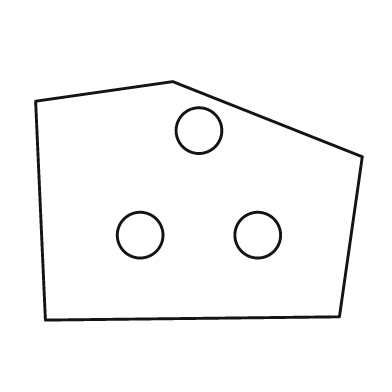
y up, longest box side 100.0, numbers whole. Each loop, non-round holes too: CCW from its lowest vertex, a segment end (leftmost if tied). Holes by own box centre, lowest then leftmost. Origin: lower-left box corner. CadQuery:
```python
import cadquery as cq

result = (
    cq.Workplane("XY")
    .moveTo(3.0, 0.0)
    .lineTo(93.0, 1.0)
    .lineTo(100.0, 50.0)
    .lineTo(42.0, 73.0)
    .lineTo(0.0, 67.0)
    .close()
    .moveTo(32.0, 26.0)
    .circle(7.0)
    .moveTo(68.0, 26.0)
    .circle(7.0)
    .moveTo(50.0, 58.0)
    .circle(7.0)
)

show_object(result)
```